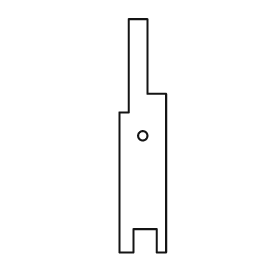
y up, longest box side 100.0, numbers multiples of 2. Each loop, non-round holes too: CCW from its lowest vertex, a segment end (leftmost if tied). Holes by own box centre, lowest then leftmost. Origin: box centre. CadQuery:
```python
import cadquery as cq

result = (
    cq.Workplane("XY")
    .moveTo(-10.0, -50.0)
    .lineTo(-4.0, -50.0)
    .lineTo(-4.0, -40.0)
    .lineTo(6.0, -40.0)
    .lineTo(6.0, -50.0)
    .lineTo(10.0, -50.0)
    .lineTo(10.0, 18.0)
    .lineTo(2.0, 18.0)
    .lineTo(2.0, 50.0)
    .lineTo(-6.0, 50.0)
    .lineTo(-6.0, 10.0)
    .lineTo(-10.0, 10.0)
    .close()
    .moveTo(0.0, 0.0)
    .circle(2.0)
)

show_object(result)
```